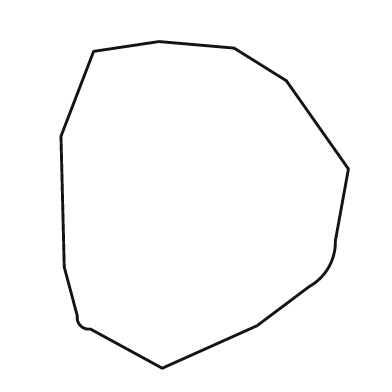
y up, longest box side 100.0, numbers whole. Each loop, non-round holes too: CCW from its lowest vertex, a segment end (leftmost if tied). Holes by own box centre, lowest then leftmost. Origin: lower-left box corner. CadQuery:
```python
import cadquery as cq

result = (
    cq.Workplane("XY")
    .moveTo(31.0, 0.0)
    .lineTo(60.0, 13.0)
    .lineTo(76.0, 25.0)
    .threePointArc((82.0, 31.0), (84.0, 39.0))
    .lineTo(88.0, 61.0)
    .lineTo(69.0, 88.0)
    .lineTo(53.0, 98.0)
    .lineTo(30.0, 100.0)
    .lineTo(10.0, 97.0)
    .lineTo(0.0, 71.0)
    .lineTo(1.0, 31.0)
    .lineTo(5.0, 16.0)
    .threePointArc((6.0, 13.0), (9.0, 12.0))
    .close()
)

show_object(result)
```